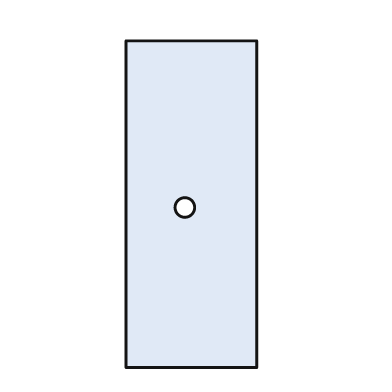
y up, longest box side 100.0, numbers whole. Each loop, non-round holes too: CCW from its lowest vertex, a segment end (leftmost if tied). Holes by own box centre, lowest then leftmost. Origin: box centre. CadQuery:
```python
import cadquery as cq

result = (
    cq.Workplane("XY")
    .moveTo(-20.0, -50.0)
    .lineTo(20.0, -50.0)
    .lineTo(20.0, 50.0)
    .lineTo(-20.0, 50.0)
    .close()
    .moveTo(-2.0, -1.0)
    .circle(3.0)
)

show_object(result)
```